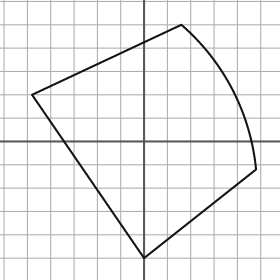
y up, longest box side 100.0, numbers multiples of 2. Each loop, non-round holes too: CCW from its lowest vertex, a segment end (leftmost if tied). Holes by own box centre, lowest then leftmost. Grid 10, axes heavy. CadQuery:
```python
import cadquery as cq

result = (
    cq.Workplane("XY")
    .moveTo(0.0, -50.0)
    .lineTo(48.0, -12.0)
    .threePointArc((38.0, 22.0), (16.0, 50.0))
    .lineTo(-48.0, 20.0)
    .close()
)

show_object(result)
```